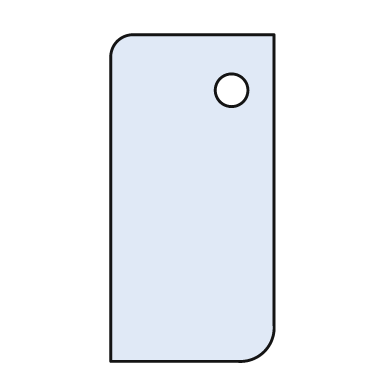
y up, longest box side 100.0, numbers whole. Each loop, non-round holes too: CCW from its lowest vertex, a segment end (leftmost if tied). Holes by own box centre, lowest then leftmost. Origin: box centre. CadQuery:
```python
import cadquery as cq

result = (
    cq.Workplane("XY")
    .moveTo(-25.0, -50.0)
    .lineTo(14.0, -50.0)
    .threePointArc((22.0, -47.0), (25.0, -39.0))
    .lineTo(25.0, 50.0)
    .lineTo(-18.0, 50.0)
    .threePointArc((-23.0, 48.0), (-25.0, 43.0))
    .close()
    .moveTo(12.0, 33.0)
    .circle(5.0)
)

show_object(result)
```